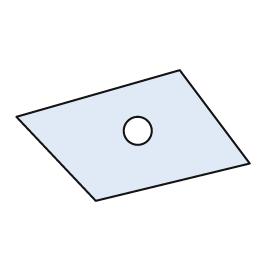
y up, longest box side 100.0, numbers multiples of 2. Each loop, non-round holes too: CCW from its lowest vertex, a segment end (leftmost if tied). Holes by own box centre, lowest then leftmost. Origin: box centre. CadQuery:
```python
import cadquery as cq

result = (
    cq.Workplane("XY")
    .moveTo(-16.0, -28.0)
    .lineTo(50.0, -12.0)
    .lineTo(20.0, 28.0)
    .lineTo(-50.0, 8.0)
    .close()
    .moveTo(2.0, 2.0)
    .circle(6.0)
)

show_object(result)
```